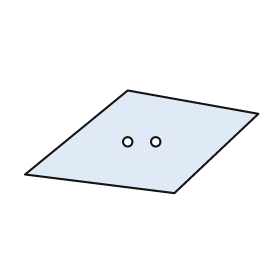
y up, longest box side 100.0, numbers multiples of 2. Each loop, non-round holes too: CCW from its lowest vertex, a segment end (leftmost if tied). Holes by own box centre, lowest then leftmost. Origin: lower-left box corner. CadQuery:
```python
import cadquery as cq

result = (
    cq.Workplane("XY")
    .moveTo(64.0, 0.0)
    .lineTo(100.0, 34.0)
    .lineTo(44.0, 44.0)
    .lineTo(0.0, 8.0)
    .close()
    .moveTo(44.0, 22.0)
    .circle(2.0)
    .moveTo(56.0, 22.0)
    .circle(2.0)
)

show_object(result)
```